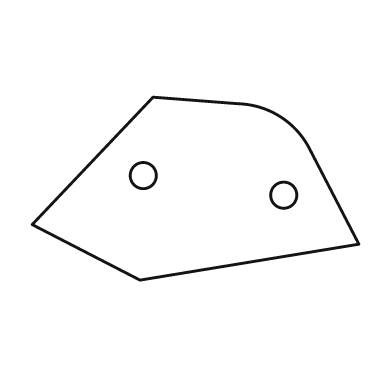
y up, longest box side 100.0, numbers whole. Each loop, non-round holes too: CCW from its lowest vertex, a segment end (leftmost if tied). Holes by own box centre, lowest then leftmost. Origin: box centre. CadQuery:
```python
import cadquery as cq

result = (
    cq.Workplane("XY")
    .moveTo(-17.0, -28.0)
    .lineTo(50.0, -17.0)
    .lineTo(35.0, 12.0)
    .threePointArc((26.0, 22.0), (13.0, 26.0))
    .lineTo(-13.0, 28.0)
    .lineTo(-50.0, -11.0)
    .close()
    .moveTo(27.0, -2.0)
    .circle(4.0)
    .moveTo(-16.0, 4.0)
    .circle(4.0)
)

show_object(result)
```